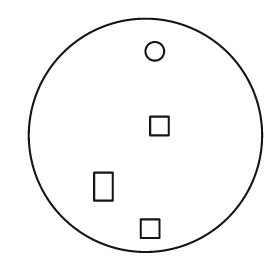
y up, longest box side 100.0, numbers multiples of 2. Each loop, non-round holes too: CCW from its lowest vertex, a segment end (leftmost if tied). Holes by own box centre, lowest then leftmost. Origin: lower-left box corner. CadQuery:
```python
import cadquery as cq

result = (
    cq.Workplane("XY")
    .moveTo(50.0, 50.0)
    .circle(50.0)
    .moveTo(48.0, 6.0)
    .lineTo(56.0, 6.0)
    .lineTo(56.0, 14.0)
    .lineTo(48.0, 14.0)
    .close()
    .moveTo(28.0, 22.0)
    .lineTo(36.0, 22.0)
    .lineTo(36.0, 34.0)
    .lineTo(28.0, 34.0)
    .close()
    .moveTo(52.0, 50.0)
    .lineTo(60.0, 50.0)
    .lineTo(60.0, 58.0)
    .lineTo(52.0, 58.0)
    .close()
    .moveTo(54.0, 86.0)
    .circle(4.0)
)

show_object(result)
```